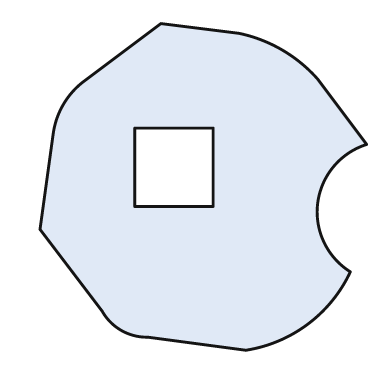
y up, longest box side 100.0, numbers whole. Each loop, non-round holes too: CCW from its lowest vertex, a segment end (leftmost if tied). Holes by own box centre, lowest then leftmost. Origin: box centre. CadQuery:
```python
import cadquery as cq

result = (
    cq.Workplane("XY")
    .moveTo(13.0, -50.0)
    .threePointArc((32.0, -42.0), (45.0, -26.0))
    .threePointArc((35.0, -5.0), (50.0, 13.0))
    .lineTo(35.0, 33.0)
    .threePointArc((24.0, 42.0), (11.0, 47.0))
    .lineTo(-13.0, 50.0)
    .lineTo(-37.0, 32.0)
    .threePointArc((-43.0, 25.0), (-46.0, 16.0))
    .lineTo(-50.0, -13.0)
    .lineTo(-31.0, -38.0)
    .threePointArc((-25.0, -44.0), (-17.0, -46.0))
    .close()
    .moveTo(-21.0, -6.0)
    .lineTo(3.0, -6.0)
    .lineTo(3.0, 18.0)
    .lineTo(-21.0, 18.0)
    .close()
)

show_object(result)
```